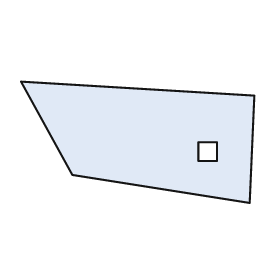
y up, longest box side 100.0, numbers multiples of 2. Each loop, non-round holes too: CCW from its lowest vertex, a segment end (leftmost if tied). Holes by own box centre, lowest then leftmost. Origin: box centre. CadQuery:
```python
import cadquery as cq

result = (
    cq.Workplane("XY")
    .moveTo(48.0, -26.0)
    .lineTo(50.0, 20.0)
    .lineTo(-50.0, 26.0)
    .lineTo(-28.0, -14.0)
    .close()
    .moveTo(26.0, -8.0)
    .lineTo(34.0, -8.0)
    .lineTo(34.0, 0.0)
    .lineTo(26.0, 0.0)
    .close()
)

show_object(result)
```